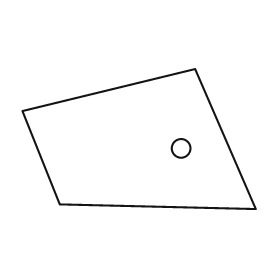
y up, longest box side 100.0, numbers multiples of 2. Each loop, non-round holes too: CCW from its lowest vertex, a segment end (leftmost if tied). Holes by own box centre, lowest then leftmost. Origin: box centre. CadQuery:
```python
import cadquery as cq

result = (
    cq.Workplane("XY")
    .moveTo(50.0, -30.0)
    .lineTo(24.0, 30.0)
    .lineTo(-50.0, 12.0)
    .lineTo(-34.0, -28.0)
    .close()
    .moveTo(18.0, -4.0)
    .circle(4.0)
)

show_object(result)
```